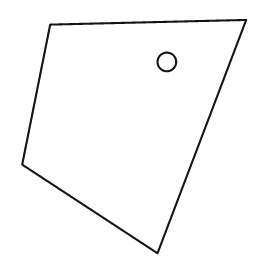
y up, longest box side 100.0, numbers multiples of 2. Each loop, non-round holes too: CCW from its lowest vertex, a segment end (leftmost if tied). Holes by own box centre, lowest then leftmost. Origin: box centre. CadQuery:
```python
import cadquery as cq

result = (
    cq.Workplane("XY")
    .moveTo(10.0, -50.0)
    .lineTo(48.0, 50.0)
    .lineTo(-36.0, 48.0)
    .lineTo(-48.0, -12.0)
    .close()
    .moveTo(14.0, 32.0)
    .circle(4.0)
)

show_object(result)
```